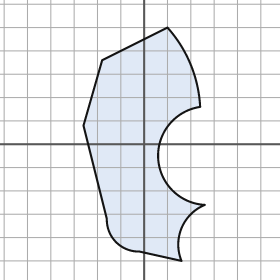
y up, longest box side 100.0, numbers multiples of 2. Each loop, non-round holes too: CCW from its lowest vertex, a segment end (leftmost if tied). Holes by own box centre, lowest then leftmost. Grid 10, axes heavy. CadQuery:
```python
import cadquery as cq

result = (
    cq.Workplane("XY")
    .moveTo(16.0, -50.0)
    .threePointArc((16.0, -36.0), (26.0, -26.0))
    .threePointArc((6.0, -6.0), (24.0, 16.0))
    .threePointArc((20.0, 34.0), (10.0, 50.0))
    .lineTo(-18.0, 36.0)
    .lineTo(-26.0, 8.0)
    .lineTo(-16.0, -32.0)
    .threePointArc((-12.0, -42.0), (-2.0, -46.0))
    .close()
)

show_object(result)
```